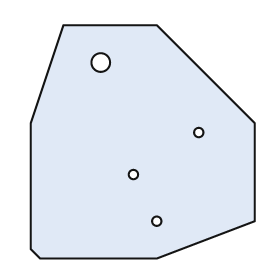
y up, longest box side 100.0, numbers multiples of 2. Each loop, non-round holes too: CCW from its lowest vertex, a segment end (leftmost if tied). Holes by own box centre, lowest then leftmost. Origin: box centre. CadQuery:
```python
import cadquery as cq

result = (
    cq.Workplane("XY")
    .moveTo(-44.0, -50.0)
    .lineTo(6.0, -50.0)
    .lineTo(48.0, -34.0)
    .lineTo(48.0, 8.0)
    .lineTo(6.0, 50.0)
    .lineTo(-34.0, 50.0)
    .lineTo(-48.0, 8.0)
    .lineTo(-48.0, -46.0)
    .close()
    .moveTo(6.0, -34.0)
    .circle(2.0)
    .moveTo(-4.0, -14.0)
    .circle(2.0)
    .moveTo(24.0, 4.0)
    .circle(2.0)
    .moveTo(-18.0, 34.0)
    .circle(4.0)
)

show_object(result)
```